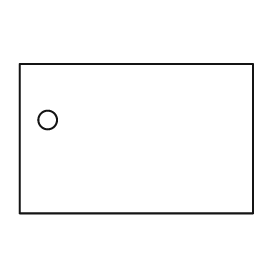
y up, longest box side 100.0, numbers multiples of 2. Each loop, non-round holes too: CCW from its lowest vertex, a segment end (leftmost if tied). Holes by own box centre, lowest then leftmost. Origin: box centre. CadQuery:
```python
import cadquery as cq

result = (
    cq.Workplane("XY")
    .moveTo(-50.0, -32.0)
    .lineTo(50.0, -32.0)
    .lineTo(50.0, 32.0)
    .lineTo(-50.0, 32.0)
    .close()
    .moveTo(-38.0, 8.0)
    .circle(4.0)
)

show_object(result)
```